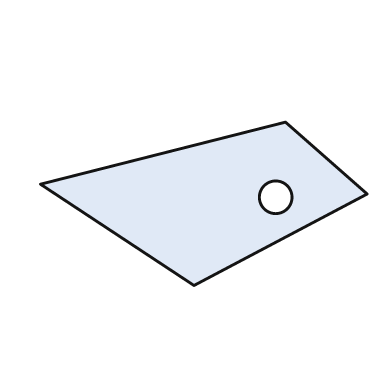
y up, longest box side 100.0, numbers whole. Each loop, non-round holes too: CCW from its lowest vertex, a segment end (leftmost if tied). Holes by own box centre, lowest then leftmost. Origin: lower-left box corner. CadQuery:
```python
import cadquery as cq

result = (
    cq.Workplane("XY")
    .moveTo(47.0, 0.0)
    .lineTo(100.0, 28.0)
    .lineTo(75.0, 50.0)
    .lineTo(0.0, 31.0)
    .close()
    .moveTo(72.0, 27.0)
    .circle(5.0)
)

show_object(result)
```